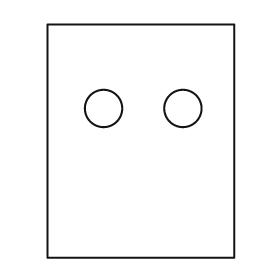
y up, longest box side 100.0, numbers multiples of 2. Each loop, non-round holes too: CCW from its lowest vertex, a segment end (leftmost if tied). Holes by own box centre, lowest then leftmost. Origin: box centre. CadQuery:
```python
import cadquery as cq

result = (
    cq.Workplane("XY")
    .moveTo(-40.0, -50.0)
    .lineTo(40.0, -50.0)
    .lineTo(40.0, 50.0)
    .lineTo(-40.0, 50.0)
    .close()
    .moveTo(-16.0, 14.0)
    .circle(8.0)
    .moveTo(18.0, 14.0)
    .circle(8.0)
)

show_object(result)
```